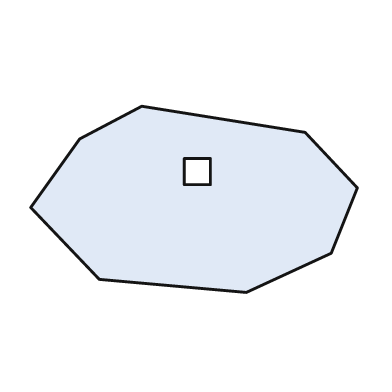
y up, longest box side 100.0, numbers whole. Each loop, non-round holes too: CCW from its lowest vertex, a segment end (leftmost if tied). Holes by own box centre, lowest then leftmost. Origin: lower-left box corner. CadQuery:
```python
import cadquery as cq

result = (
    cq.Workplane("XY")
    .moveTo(66.0, 0.0)
    .lineTo(92.0, 12.0)
    .lineTo(100.0, 32.0)
    .lineTo(84.0, 49.0)
    .lineTo(34.0, 57.0)
    .lineTo(15.0, 47.0)
    .lineTo(0.0, 26.0)
    .lineTo(21.0, 4.0)
    .close()
    .moveTo(47.0, 33.0)
    .lineTo(55.0, 33.0)
    .lineTo(55.0, 41.0)
    .lineTo(47.0, 41.0)
    .close()
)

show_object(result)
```